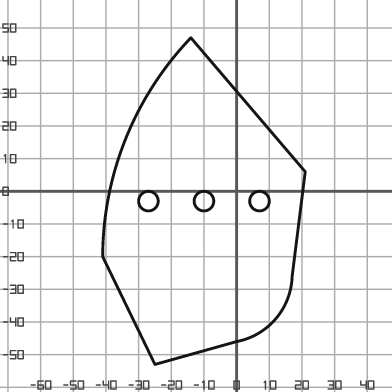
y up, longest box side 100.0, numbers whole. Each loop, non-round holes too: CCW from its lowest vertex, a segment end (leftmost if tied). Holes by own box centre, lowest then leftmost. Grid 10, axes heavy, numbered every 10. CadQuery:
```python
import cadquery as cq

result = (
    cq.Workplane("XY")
    .moveTo(-25.0, -53.0)
    .lineTo(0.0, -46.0)
    .threePointArc((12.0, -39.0), (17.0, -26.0))
    .lineTo(21.0, 6.0)
    .lineTo(-14.0, 47.0)
    .threePointArc((-34.0, 16.0), (-41.0, -20.0))
    .close()
    .moveTo(-27.0, -3.0)
    .circle(3.0)
    .moveTo(-10.0, -3.0)
    .circle(3.0)
    .moveTo(7.0, -3.0)
    .circle(3.0)
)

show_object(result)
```